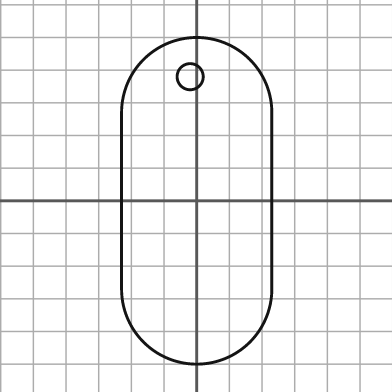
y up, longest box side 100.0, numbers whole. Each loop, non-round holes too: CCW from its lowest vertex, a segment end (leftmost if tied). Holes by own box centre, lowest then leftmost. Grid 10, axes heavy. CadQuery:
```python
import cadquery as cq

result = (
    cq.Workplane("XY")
    .moveTo(-23.0, -27.0)
    .threePointArc((0.0, -50.0), (23.0, -27.0))
    .lineTo(23.0, 27.0)
    .threePointArc((0.0, 50.0), (-23.0, 27.0))
    .close()
    .moveTo(-2.0, 38.0)
    .circle(4.0)
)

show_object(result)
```